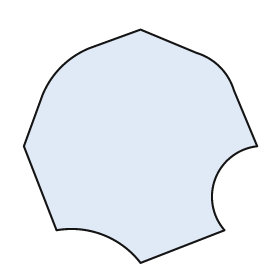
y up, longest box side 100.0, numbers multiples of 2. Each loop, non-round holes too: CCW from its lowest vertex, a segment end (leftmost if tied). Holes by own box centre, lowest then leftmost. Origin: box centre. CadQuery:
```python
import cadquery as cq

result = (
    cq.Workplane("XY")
    .moveTo(0.0, -50.0)
    .lineTo(36.0, -36.0)
    .threePointArc((32.0, -14.0), (50.0, 0.0))
    .lineTo(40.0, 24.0)
    .threePointArc((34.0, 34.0), (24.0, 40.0))
    .lineTo(0.0, 50.0)
    .lineTo(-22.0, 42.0)
    .threePointArc((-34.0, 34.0), (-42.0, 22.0))
    .lineTo(-50.0, 0.0)
    .lineTo(-36.0, -36.0)
    .threePointArc((-16.0, -38.0), (0.0, -50.0))
    .close()
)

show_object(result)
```